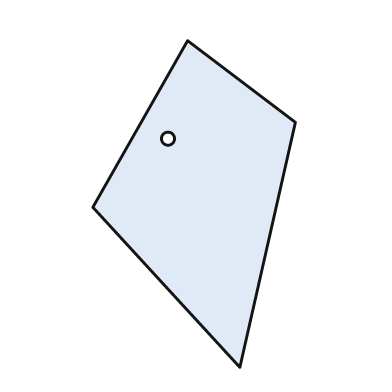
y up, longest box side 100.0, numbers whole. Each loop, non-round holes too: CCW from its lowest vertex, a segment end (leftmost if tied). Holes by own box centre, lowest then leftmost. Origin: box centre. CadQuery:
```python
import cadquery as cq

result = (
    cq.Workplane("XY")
    .moveTo(14.0, -50.0)
    .lineTo(31.0, 25.0)
    .lineTo(-2.0, 50.0)
    .lineTo(-31.0, -1.0)
    .close()
    .moveTo(-8.0, 20.0)
    .circle(2.0)
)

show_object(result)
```